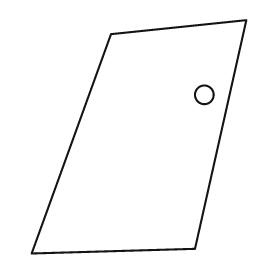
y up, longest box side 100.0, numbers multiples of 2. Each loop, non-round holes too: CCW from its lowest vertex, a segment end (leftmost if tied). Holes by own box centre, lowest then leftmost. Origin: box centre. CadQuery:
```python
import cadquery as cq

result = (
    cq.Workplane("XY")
    .moveTo(-46.0, -50.0)
    .lineTo(24.0, -48.0)
    .lineTo(46.0, 50.0)
    .lineTo(-12.0, 44.0)
    .close()
    .moveTo(28.0, 18.0)
    .circle(4.0)
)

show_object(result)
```